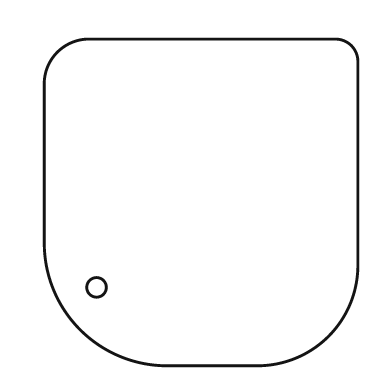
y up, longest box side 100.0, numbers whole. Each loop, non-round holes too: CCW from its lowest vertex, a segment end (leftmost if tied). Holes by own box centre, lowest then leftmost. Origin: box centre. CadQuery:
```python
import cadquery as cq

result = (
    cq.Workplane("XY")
    .moveTo(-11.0, -50.0)
    .lineTo(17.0, -50.0)
    .threePointArc((39.0, -41.0), (48.0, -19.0))
    .lineTo(48.0, 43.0)
    .threePointArc((46.0, 48.0), (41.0, 50.0))
    .lineTo(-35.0, 50.0)
    .threePointArc((-44.0, 46.0), (-48.0, 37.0))
    .lineTo(-48.0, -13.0)
    .threePointArc((-37.0, -39.0), (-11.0, -50.0))
    .close()
    .moveTo(-32.0, -26.0)
    .circle(3.0)
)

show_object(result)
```